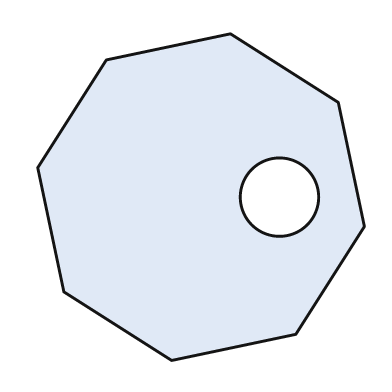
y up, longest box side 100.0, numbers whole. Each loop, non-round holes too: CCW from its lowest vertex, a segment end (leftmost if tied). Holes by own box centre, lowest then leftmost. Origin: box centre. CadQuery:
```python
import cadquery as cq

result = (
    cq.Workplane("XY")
    .moveTo(-9.0, -50.0)
    .lineTo(29.0, -42.0)
    .lineTo(50.0, -9.0)
    .lineTo(42.0, 29.0)
    .lineTo(9.0, 50.0)
    .lineTo(-29.0, 42.0)
    .lineTo(-50.0, 9.0)
    .lineTo(-42.0, -29.0)
    .close()
    .moveTo(24.0, 0.0)
    .circle(12.0)
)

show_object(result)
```